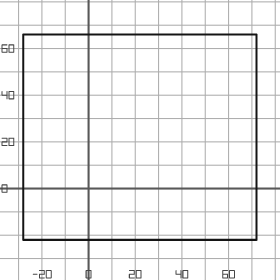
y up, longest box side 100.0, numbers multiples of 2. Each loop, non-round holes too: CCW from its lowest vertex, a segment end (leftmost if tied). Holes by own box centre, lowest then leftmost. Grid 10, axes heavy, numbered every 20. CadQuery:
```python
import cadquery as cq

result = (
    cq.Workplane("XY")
    .moveTo(-28.0, -22.0)
    .lineTo(72.0, -22.0)
    .lineTo(72.0, 66.0)
    .lineTo(-28.0, 66.0)
    .close()
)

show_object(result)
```